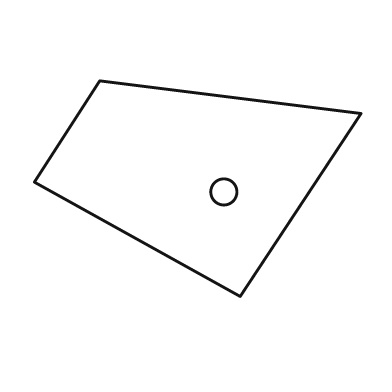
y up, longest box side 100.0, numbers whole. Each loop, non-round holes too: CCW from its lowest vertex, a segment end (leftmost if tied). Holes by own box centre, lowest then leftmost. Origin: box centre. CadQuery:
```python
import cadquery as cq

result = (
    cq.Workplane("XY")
    .moveTo(13.0, -33.0)
    .lineTo(50.0, 23.0)
    .lineTo(-30.0, 33.0)
    .lineTo(-50.0, 2.0)
    .close()
    .moveTo(8.0, -1.0)
    .circle(4.0)
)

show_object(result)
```